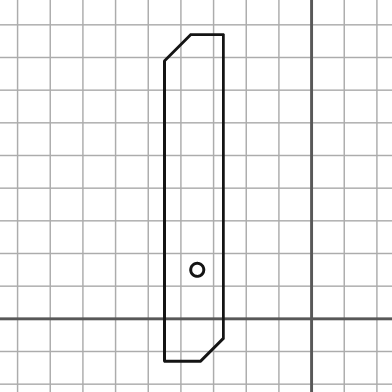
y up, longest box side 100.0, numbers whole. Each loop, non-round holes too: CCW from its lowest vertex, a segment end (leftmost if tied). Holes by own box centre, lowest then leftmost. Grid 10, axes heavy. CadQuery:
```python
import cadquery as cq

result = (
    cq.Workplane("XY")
    .moveTo(-45.0, -13.0)
    .lineTo(-34.0, -13.0)
    .lineTo(-27.0, -6.0)
    .lineTo(-27.0, 87.0)
    .lineTo(-37.0, 87.0)
    .lineTo(-45.0, 79.0)
    .close()
    .moveTo(-35.0, 15.0)
    .circle(2.0)
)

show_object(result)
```